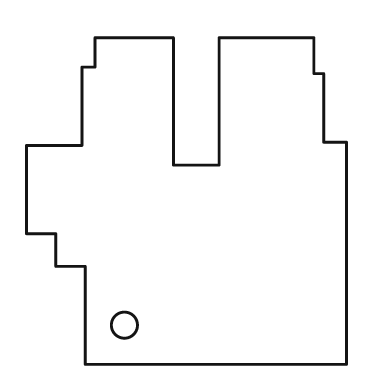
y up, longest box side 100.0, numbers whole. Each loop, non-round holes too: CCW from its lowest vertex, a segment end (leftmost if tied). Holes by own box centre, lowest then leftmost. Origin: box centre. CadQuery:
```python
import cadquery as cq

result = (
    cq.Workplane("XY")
    .moveTo(-31.0, -50.0)
    .lineTo(49.0, -50.0)
    .lineTo(49.0, 18.0)
    .lineTo(42.0, 18.0)
    .lineTo(42.0, 39.0)
    .lineTo(39.0, 39.0)
    .lineTo(39.0, 50.0)
    .lineTo(10.0, 50.0)
    .lineTo(10.0, 11.0)
    .lineTo(-4.0, 11.0)
    .lineTo(-4.0, 50.0)
    .lineTo(-28.0, 50.0)
    .lineTo(-28.0, 41.0)
    .lineTo(-32.0, 41.0)
    .lineTo(-32.0, 17.0)
    .lineTo(-49.0, 17.0)
    .lineTo(-49.0, -10.0)
    .lineTo(-40.0, -10.0)
    .lineTo(-40.0, -20.0)
    .lineTo(-31.0, -20.0)
    .close()
    .moveTo(-19.0, -38.0)
    .circle(4.0)
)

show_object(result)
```